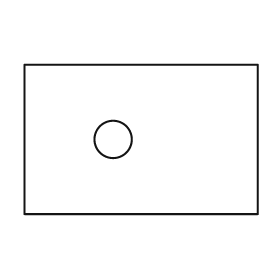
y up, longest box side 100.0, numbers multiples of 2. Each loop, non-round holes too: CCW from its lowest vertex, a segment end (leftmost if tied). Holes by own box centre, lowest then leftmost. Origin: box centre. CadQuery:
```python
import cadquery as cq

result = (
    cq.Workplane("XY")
    .moveTo(-50.0, -32.0)
    .lineTo(50.0, -32.0)
    .lineTo(50.0, 32.0)
    .lineTo(-50.0, 32.0)
    .close()
    .moveTo(-12.0, 0.0)
    .circle(8.0)
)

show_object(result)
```